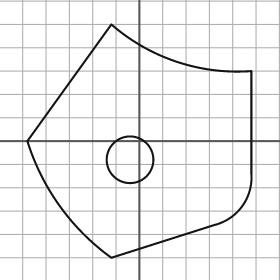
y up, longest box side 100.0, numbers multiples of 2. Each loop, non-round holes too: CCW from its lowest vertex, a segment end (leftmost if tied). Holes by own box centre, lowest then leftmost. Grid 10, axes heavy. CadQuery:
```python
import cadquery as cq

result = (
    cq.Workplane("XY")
    .moveTo(-12.0, -50.0)
    .lineTo(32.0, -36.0)
    .threePointArc((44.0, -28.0), (48.0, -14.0))
    .lineTo(48.0, 30.0)
    .threePointArc((16.0, 34.0), (-12.0, 50.0))
    .lineTo(-48.0, 0.0)
    .threePointArc((-34.0, -28.0), (-12.0, -50.0))
    .close()
    .moveTo(-4.0, -8.0)
    .circle(10.0)
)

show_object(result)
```